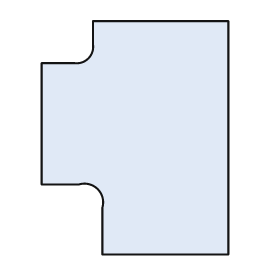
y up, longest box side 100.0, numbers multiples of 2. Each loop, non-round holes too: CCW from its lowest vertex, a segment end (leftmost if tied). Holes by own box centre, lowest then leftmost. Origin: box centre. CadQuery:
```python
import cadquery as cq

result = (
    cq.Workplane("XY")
    .moveTo(-14.0, -50.0)
    .lineTo(40.0, -50.0)
    .lineTo(40.0, 50.0)
    .lineTo(-18.0, 50.0)
    .lineTo(-18.0, 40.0)
    .threePointArc((-20.0, 34.0), (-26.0, 32.0))
    .lineTo(-40.0, 32.0)
    .lineTo(-40.0, -20.0)
    .lineTo(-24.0, -20.0)
    .threePointArc((-16.0, -22.0), (-14.0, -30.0))
    .close()
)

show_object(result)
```